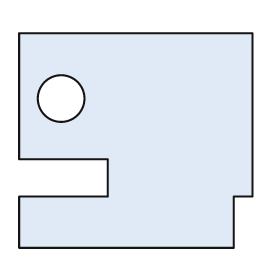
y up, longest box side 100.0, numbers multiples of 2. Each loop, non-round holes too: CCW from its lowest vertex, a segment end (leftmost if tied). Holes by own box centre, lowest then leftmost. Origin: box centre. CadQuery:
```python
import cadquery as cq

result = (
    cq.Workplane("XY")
    .moveTo(-50.0, -46.0)
    .lineTo(42.0, -46.0)
    .lineTo(42.0, -24.0)
    .lineTo(50.0, -24.0)
    .lineTo(50.0, 46.0)
    .lineTo(-50.0, 46.0)
    .lineTo(-50.0, -8.0)
    .lineTo(-12.0, -8.0)
    .lineTo(-12.0, -24.0)
    .lineTo(-50.0, -24.0)
    .close()
    .moveTo(-32.0, 18.0)
    .circle(10.0)
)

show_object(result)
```